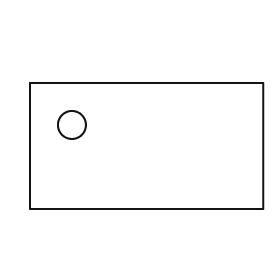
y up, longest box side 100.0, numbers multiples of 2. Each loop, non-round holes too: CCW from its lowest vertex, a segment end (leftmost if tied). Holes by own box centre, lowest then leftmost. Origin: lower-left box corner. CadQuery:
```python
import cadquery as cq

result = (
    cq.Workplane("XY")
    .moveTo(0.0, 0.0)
    .lineTo(100.0, 0.0)
    .lineTo(100.0, 54.0)
    .lineTo(0.0, 54.0)
    .close()
    .moveTo(18.0, 36.0)
    .circle(6.0)
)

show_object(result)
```